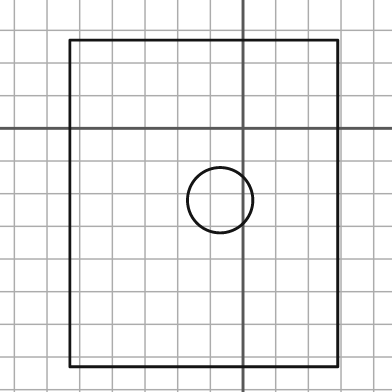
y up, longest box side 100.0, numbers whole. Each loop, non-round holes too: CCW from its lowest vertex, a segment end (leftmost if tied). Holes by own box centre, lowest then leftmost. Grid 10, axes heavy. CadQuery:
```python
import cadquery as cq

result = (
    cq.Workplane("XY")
    .moveTo(-53.0, -73.0)
    .lineTo(29.0, -73.0)
    .lineTo(29.0, 27.0)
    .lineTo(-53.0, 27.0)
    .close()
    .moveTo(-7.0, -22.0)
    .circle(10.0)
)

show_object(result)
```